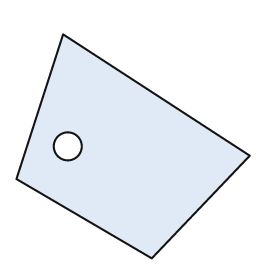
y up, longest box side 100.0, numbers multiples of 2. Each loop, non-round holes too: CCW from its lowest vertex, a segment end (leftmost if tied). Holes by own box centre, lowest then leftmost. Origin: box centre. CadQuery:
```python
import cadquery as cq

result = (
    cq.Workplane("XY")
    .moveTo(8.0, -48.0)
    .lineTo(50.0, -4.0)
    .lineTo(-30.0, 48.0)
    .lineTo(-50.0, -14.0)
    .close()
    .moveTo(-28.0, 0.0)
    .circle(6.0)
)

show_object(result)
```